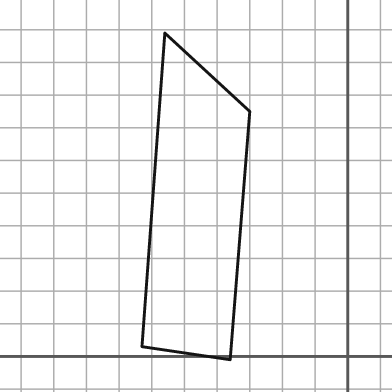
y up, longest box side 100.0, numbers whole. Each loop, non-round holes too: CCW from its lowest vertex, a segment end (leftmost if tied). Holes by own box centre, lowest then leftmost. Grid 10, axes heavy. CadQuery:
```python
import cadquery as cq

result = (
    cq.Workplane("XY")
    .moveTo(-36.0, -1.0)
    .lineTo(-30.0, 75.0)
    .lineTo(-56.0, 99.0)
    .lineTo(-63.0, 3.0)
    .close()
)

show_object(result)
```